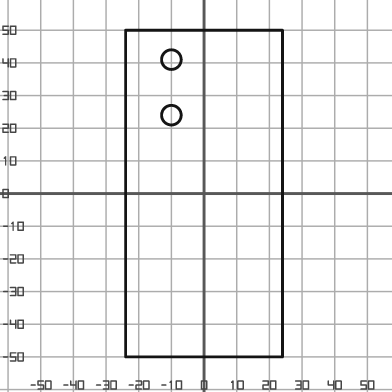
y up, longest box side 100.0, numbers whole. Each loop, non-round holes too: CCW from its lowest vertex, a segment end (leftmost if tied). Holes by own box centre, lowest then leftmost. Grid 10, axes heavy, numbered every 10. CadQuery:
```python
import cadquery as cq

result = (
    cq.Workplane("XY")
    .moveTo(-24.0, -50.0)
    .lineTo(24.0, -50.0)
    .lineTo(24.0, 50.0)
    .lineTo(-24.0, 50.0)
    .close()
    .moveTo(-10.0, 24.0)
    .circle(3.0)
    .moveTo(-10.0, 41.0)
    .circle(3.0)
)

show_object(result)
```